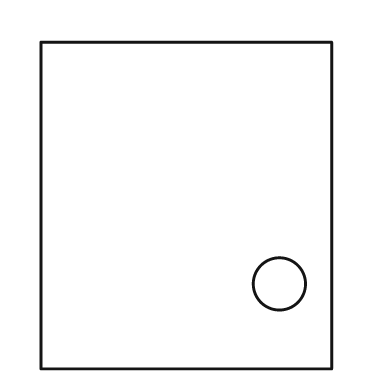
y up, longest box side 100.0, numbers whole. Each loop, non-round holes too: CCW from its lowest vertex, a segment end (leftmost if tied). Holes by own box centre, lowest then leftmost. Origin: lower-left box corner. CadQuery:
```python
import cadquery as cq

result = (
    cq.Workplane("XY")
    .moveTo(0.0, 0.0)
    .lineTo(89.0, 0.0)
    .lineTo(89.0, 100.0)
    .lineTo(0.0, 100.0)
    .close()
    .moveTo(73.0, 26.0)
    .circle(8.0)
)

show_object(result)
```